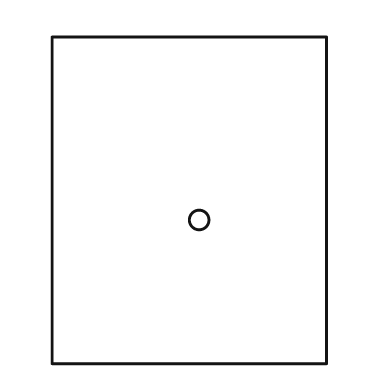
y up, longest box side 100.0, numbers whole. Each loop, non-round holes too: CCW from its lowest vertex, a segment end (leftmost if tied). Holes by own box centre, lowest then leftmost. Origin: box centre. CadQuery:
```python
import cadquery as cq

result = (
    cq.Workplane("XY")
    .moveTo(-42.0, -50.0)
    .lineTo(42.0, -50.0)
    .lineTo(42.0, 50.0)
    .lineTo(-42.0, 50.0)
    .close()
    .moveTo(3.0, -6.0)
    .circle(3.0)
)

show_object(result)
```